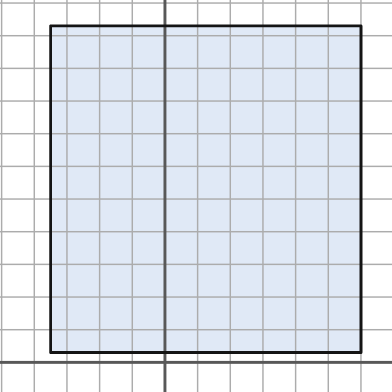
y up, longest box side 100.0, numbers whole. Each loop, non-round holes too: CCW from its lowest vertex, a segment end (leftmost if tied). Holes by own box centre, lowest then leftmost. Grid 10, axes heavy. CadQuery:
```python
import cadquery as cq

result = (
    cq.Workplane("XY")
    .moveTo(-35.0, 3.0)
    .lineTo(60.0, 3.0)
    .lineTo(60.0, 103.0)
    .lineTo(-35.0, 103.0)
    .close()
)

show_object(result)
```